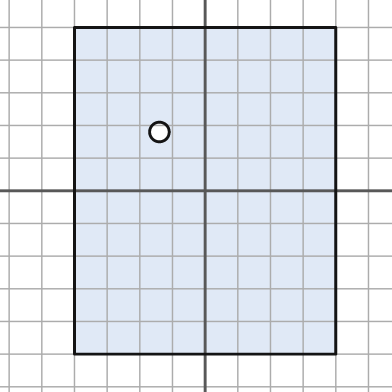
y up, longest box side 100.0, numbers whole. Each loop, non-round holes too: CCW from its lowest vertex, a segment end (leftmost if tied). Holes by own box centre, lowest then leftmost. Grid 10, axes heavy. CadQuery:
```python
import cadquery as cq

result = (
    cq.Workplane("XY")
    .moveTo(-40.0, -50.0)
    .lineTo(40.0, -50.0)
    .lineTo(40.0, 50.0)
    .lineTo(-40.0, 50.0)
    .close()
    .moveTo(-14.0, 18.0)
    .circle(3.0)
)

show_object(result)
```